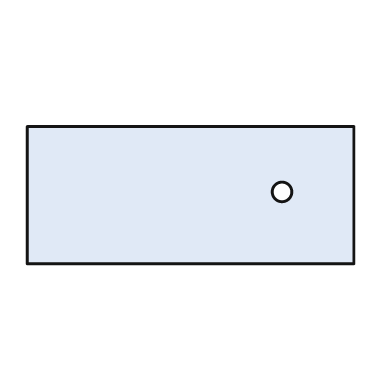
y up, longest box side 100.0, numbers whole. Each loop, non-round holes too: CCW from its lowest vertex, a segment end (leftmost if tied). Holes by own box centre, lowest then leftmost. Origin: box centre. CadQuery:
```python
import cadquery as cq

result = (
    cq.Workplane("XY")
    .moveTo(-50.0, -21.0)
    .lineTo(50.0, -21.0)
    .lineTo(50.0, 21.0)
    .lineTo(-50.0, 21.0)
    .close()
    .moveTo(28.0, 1.0)
    .circle(3.0)
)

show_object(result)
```